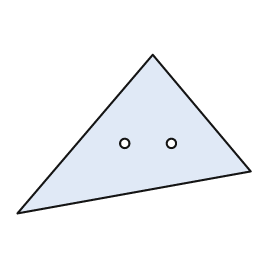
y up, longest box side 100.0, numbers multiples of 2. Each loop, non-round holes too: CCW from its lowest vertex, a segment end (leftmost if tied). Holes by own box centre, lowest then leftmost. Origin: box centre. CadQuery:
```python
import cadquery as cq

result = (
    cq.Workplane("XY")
    .moveTo(-50.0, -34.0)
    .lineTo(50.0, -16.0)
    .lineTo(8.0, 34.0)
    .close()
    .moveTo(-4.0, -4.0)
    .circle(2.0)
    .moveTo(16.0, -4.0)
    .circle(2.0)
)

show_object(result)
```